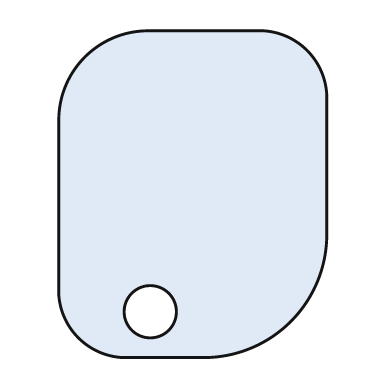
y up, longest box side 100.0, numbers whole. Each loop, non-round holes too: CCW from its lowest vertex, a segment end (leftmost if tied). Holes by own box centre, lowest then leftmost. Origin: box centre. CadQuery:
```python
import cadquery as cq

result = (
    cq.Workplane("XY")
    .moveTo(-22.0, -50.0)
    .lineTo(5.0, -50.0)
    .threePointArc((30.0, -39.0), (41.0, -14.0))
    .lineTo(41.0, 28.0)
    .threePointArc((35.0, 44.0), (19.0, 50.0))
    .lineTo(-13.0, 50.0)
    .threePointArc((-33.0, 42.0), (-41.0, 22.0))
    .lineTo(-41.0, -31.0)
    .threePointArc((-35.0, -44.0), (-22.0, -50.0))
    .close()
    .moveTo(-13.0, -36.0)
    .circle(8.0)
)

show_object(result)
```